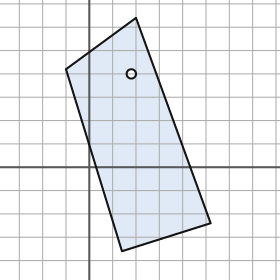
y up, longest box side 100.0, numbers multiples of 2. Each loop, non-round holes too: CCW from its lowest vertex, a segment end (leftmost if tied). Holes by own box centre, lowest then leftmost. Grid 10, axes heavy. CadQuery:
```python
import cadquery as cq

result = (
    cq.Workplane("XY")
    .moveTo(14.0, -36.0)
    .lineTo(52.0, -24.0)
    .lineTo(20.0, 64.0)
    .lineTo(-10.0, 42.0)
    .close()
    .moveTo(18.0, 40.0)
    .circle(2.0)
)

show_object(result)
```